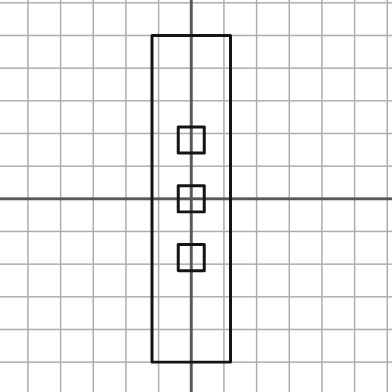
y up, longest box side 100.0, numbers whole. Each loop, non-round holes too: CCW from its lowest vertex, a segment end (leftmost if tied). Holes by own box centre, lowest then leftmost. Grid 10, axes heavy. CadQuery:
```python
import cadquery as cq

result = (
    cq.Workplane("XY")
    .moveTo(-12.0, -50.0)
    .lineTo(12.0, -50.0)
    .lineTo(12.0, 50.0)
    .lineTo(-12.0, 50.0)
    .close()
    .moveTo(-4.0, -22.0)
    .lineTo(4.0, -22.0)
    .lineTo(4.0, -14.0)
    .lineTo(-4.0, -14.0)
    .close()
    .moveTo(-4.0, -4.0)
    .lineTo(4.0, -4.0)
    .lineTo(4.0, 4.0)
    .lineTo(-4.0, 4.0)
    .close()
    .moveTo(-4.0, 14.0)
    .lineTo(4.0, 14.0)
    .lineTo(4.0, 22.0)
    .lineTo(-4.0, 22.0)
    .close()
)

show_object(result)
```